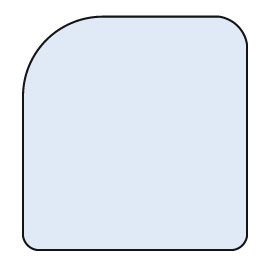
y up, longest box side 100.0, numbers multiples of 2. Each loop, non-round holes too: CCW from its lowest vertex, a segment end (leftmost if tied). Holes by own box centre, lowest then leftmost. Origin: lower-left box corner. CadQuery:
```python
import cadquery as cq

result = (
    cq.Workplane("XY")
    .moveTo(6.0, 0.0)
    .lineTo(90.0, 0.0)
    .threePointArc((94.0, 2.0), (96.0, 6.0))
    .lineTo(96.0, 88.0)
    .threePointArc((92.0, 96.0), (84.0, 100.0))
    .lineTo(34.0, 100.0)
    .threePointArc((10.0, 90.0), (0.0, 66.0))
    .lineTo(0.0, 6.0)
    .threePointArc((2.0, 2.0), (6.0, 0.0))
    .close()
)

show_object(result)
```